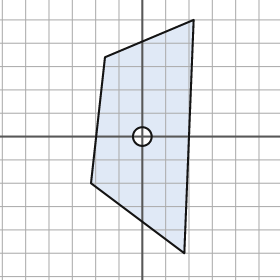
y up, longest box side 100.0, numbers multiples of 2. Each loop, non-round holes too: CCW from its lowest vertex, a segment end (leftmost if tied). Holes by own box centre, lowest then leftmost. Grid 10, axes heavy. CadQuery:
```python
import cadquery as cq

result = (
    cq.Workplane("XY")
    .moveTo(18.0, -50.0)
    .lineTo(22.0, 50.0)
    .lineTo(-16.0, 34.0)
    .lineTo(-22.0, -20.0)
    .close()
    .moveTo(0.0, 0.0)
    .circle(4.0)
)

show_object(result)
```